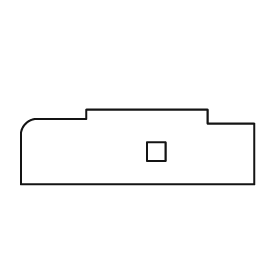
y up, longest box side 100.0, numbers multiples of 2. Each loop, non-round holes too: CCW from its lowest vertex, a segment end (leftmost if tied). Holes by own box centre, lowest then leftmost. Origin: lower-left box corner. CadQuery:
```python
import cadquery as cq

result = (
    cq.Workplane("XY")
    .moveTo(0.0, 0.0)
    .lineTo(100.0, 0.0)
    .lineTo(100.0, 26.0)
    .lineTo(80.0, 26.0)
    .lineTo(80.0, 32.0)
    .lineTo(28.0, 32.0)
    .lineTo(28.0, 28.0)
    .lineTo(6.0, 28.0)
    .threePointArc((2.0, 26.0), (0.0, 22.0))
    .close()
    .moveTo(54.0, 10.0)
    .lineTo(62.0, 10.0)
    .lineTo(62.0, 18.0)
    .lineTo(54.0, 18.0)
    .close()
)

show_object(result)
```